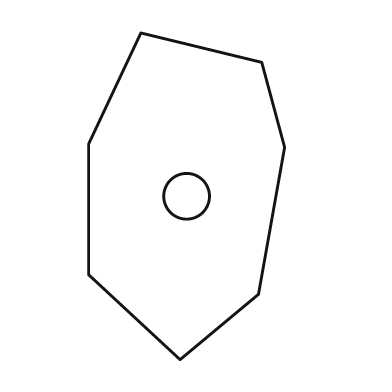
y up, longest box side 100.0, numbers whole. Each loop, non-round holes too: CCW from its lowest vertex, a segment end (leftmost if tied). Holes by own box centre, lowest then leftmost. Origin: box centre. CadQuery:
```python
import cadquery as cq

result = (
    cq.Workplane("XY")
    .moveTo(-2.0, -50.0)
    .lineTo(22.0, -30.0)
    .lineTo(30.0, 15.0)
    .lineTo(23.0, 41.0)
    .lineTo(-14.0, 50.0)
    .lineTo(-30.0, 16.0)
    .lineTo(-30.0, -24.0)
    .close()
    .moveTo(0.0, 0.0)
    .circle(7.0)
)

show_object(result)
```